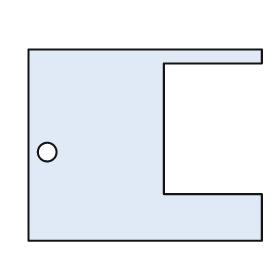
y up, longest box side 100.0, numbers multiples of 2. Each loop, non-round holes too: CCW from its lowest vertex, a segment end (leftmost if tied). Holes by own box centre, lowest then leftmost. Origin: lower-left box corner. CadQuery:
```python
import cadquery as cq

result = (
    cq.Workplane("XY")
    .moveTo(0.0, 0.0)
    .lineTo(100.0, 0.0)
    .lineTo(100.0, 20.0)
    .lineTo(58.0, 20.0)
    .lineTo(58.0, 76.0)
    .lineTo(100.0, 76.0)
    .lineTo(100.0, 82.0)
    .lineTo(0.0, 82.0)
    .close()
    .moveTo(8.0, 38.0)
    .circle(4.0)
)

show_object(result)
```